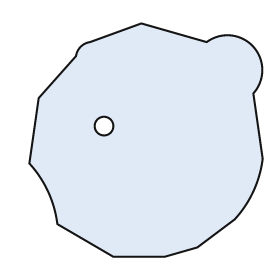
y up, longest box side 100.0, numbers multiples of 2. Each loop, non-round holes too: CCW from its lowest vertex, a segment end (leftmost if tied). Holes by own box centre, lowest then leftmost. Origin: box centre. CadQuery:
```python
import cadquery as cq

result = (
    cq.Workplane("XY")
    .moveTo(-14.0, -50.0)
    .lineTo(8.0, -50.0)
    .lineTo(22.0, -46.0)
    .lineTo(38.0, -34.0)
    .threePointArc((46.0, -22.0), (50.0, -8.0))
    .lineTo(46.0, 20.0)
    .threePointArc((46.0, 40.0), (26.0, 42.0))
    .lineTo(-2.0, 50.0)
    .lineTo(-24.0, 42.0)
    .threePointArc((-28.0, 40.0), (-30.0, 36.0))
    .lineTo(-46.0, 18.0)
    .lineTo(-50.0, -10.0)
    .threePointArc((-42.0, -22.0), (-38.0, -36.0))
    .close()
    .moveTo(-18.0, 6.0)
    .circle(4.0)
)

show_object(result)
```